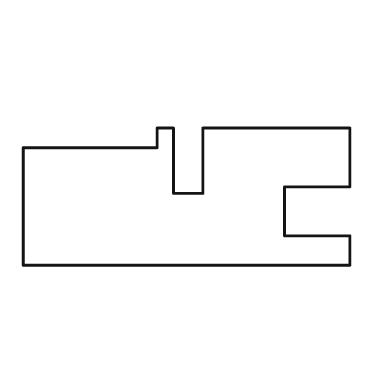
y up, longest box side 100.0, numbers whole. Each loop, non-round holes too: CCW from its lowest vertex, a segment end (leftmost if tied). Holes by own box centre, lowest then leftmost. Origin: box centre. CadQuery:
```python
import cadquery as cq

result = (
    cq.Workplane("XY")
    .moveTo(-50.0, -21.0)
    .lineTo(50.0, -21.0)
    .lineTo(50.0, -12.0)
    .lineTo(30.0, -12.0)
    .lineTo(30.0, 3.0)
    .lineTo(50.0, 3.0)
    .lineTo(50.0, 21.0)
    .lineTo(5.0, 21.0)
    .lineTo(5.0, 1.0)
    .lineTo(-4.0, 1.0)
    .lineTo(-4.0, 21.0)
    .lineTo(-9.0, 21.0)
    .lineTo(-9.0, 15.0)
    .lineTo(-50.0, 15.0)
    .close()
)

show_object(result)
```